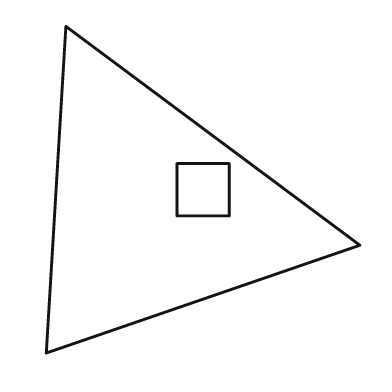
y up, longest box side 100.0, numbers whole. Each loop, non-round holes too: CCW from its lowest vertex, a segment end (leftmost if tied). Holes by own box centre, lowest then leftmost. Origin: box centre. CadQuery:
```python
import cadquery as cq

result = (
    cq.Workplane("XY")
    .moveTo(-48.0, -50.0)
    .lineTo(48.0, -17.0)
    .lineTo(-42.0, 50.0)
    .close()
    .moveTo(-8.0, -8.0)
    .lineTo(8.0, -8.0)
    .lineTo(8.0, 8.0)
    .lineTo(-8.0, 8.0)
    .close()
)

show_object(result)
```